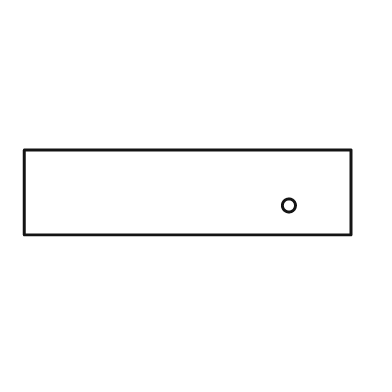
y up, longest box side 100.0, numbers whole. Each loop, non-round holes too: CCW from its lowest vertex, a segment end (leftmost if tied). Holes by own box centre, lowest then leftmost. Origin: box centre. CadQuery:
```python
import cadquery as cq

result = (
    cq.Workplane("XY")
    .moveTo(-50.0, -13.0)
    .lineTo(50.0, -13.0)
    .lineTo(50.0, 13.0)
    .lineTo(-50.0, 13.0)
    .close()
    .moveTo(31.0, -4.0)
    .circle(2.0)
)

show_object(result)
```